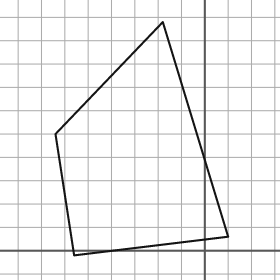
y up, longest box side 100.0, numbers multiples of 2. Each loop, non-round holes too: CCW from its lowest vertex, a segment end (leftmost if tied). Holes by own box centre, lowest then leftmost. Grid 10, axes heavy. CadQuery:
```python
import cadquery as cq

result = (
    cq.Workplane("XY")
    .moveTo(-56.0, -2.0)
    .lineTo(10.0, 6.0)
    .lineTo(-18.0, 98.0)
    .lineTo(-64.0, 50.0)
    .close()
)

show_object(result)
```